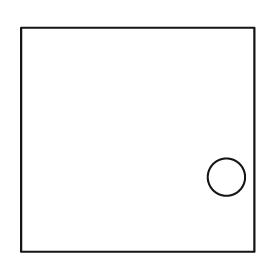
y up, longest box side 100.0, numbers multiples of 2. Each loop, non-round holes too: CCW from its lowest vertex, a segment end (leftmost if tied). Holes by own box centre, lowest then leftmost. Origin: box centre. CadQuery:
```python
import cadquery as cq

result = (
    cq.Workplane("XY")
    .moveTo(-50.0, -48.0)
    .lineTo(50.0, -48.0)
    .lineTo(50.0, 48.0)
    .lineTo(-50.0, 48.0)
    .close()
    .moveTo(38.0, -16.0)
    .circle(8.0)
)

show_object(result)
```